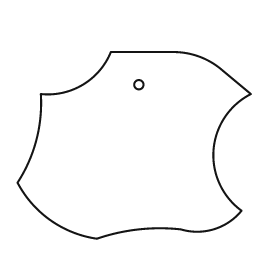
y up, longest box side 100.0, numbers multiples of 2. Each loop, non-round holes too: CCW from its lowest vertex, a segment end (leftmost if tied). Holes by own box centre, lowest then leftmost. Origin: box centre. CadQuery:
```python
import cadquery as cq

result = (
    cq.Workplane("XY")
    .moveTo(-16.0, -40.0)
    .threePointArc((2.0, -36.0), (20.0, -36.0))
    .threePointArc((34.0, -36.0), (46.0, -28.0))
    .threePointArc((34.0, -2.0), (50.0, 22.0))
    .lineTo(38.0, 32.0)
    .threePointArc((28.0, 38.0), (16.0, 40.0))
    .lineTo(-10.0, 40.0)
    .threePointArc((-22.0, 26.0), (-40.0, 22.0))
    .threePointArc((-42.0, 2.0), (-50.0, -16.0))
    .threePointArc((-36.0, -32.0), (-16.0, -40.0))
    .close()
    .moveTo(2.0, 26.0)
    .circle(2.0)
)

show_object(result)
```